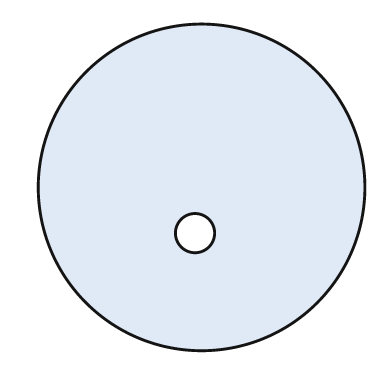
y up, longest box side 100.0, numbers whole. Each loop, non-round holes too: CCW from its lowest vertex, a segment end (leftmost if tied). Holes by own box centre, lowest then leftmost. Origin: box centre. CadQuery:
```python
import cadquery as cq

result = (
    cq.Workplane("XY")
    .moveTo(0.0, 0.0)
    .circle(50.0)
    .moveTo(-2.0, -14.0)
    .circle(6.0)
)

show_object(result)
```